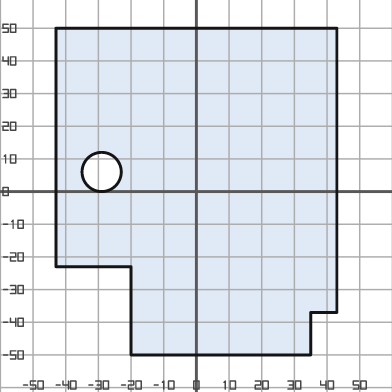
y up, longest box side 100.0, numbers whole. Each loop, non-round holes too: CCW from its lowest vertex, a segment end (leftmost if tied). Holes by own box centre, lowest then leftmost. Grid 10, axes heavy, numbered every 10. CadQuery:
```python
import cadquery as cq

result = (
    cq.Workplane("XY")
    .moveTo(-20.0, -50.0)
    .lineTo(35.0, -50.0)
    .lineTo(35.0, -37.0)
    .lineTo(43.0, -37.0)
    .lineTo(43.0, 50.0)
    .lineTo(-43.0, 50.0)
    .lineTo(-43.0, -23.0)
    .lineTo(-20.0, -23.0)
    .close()
    .moveTo(-29.0, 6.0)
    .circle(6.0)
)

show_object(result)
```